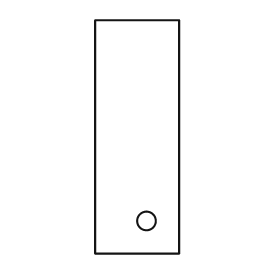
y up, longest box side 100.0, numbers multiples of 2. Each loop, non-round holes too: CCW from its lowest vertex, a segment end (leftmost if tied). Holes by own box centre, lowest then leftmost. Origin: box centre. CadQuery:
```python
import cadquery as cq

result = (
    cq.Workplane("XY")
    .moveTo(-18.0, -50.0)
    .lineTo(18.0, -50.0)
    .lineTo(18.0, 50.0)
    .lineTo(-18.0, 50.0)
    .close()
    .moveTo(4.0, -36.0)
    .circle(4.0)
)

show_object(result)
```